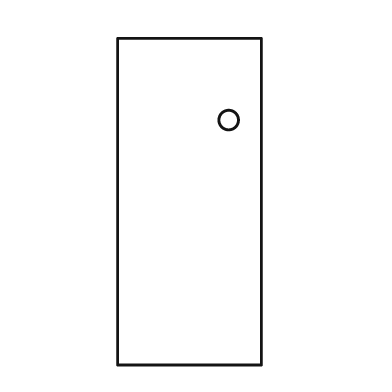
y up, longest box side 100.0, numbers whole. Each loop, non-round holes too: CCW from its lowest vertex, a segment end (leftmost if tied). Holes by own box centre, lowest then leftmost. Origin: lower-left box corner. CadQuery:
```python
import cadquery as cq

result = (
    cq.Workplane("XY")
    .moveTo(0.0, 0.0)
    .lineTo(44.0, 0.0)
    .lineTo(44.0, 100.0)
    .lineTo(0.0, 100.0)
    .close()
    .moveTo(34.0, 75.0)
    .circle(3.0)
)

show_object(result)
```